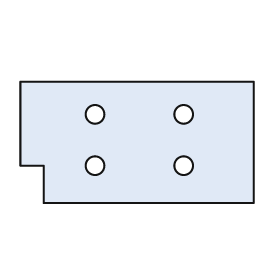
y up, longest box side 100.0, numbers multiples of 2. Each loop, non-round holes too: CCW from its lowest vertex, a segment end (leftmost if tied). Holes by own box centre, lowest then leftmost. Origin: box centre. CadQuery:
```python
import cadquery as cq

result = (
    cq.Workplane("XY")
    .moveTo(-40.0, -26.0)
    .lineTo(50.0, -26.0)
    .lineTo(50.0, 26.0)
    .lineTo(-50.0, 26.0)
    .lineTo(-50.0, -10.0)
    .lineTo(-40.0, -10.0)
    .close()
    .moveTo(-18.0, -10.0)
    .circle(4.0)
    .moveTo(20.0, -10.0)
    .circle(4.0)
    .moveTo(-18.0, 12.0)
    .circle(4.0)
    .moveTo(20.0, 12.0)
    .circle(4.0)
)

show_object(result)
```